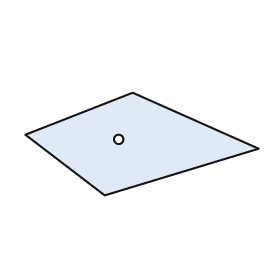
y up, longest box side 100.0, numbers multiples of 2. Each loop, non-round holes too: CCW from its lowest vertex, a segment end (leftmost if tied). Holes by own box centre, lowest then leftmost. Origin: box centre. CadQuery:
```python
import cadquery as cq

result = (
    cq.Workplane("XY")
    .moveTo(-16.0, -22.0)
    .lineTo(50.0, -2.0)
    .lineTo(-4.0, 22.0)
    .lineTo(-50.0, 4.0)
    .close()
    .moveTo(-10.0, 2.0)
    .circle(2.0)
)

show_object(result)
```